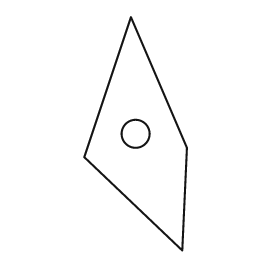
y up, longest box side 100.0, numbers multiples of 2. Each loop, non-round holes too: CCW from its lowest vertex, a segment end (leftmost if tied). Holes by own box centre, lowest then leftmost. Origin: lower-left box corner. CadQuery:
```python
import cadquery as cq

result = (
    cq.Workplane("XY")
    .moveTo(42.0, 0.0)
    .lineTo(44.0, 44.0)
    .lineTo(20.0, 100.0)
    .lineTo(0.0, 40.0)
    .close()
    .moveTo(22.0, 50.0)
    .circle(6.0)
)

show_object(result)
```